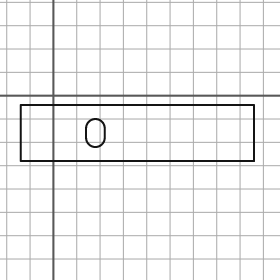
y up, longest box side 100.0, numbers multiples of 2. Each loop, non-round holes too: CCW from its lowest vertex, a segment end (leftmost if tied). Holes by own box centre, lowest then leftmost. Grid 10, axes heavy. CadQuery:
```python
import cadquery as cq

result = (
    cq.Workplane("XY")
    .moveTo(-14.0, -28.0)
    .lineTo(86.0, -28.0)
    .lineTo(86.0, -4.0)
    .lineTo(-14.0, -4.0)
    .close()
    .moveTo(14.0, -18.0)
    .threePointArc((18.0, -22.0), (22.0, -18.0))
    .lineTo(22.0, -14.0)
    .threePointArc((18.0, -10.0), (14.0, -14.0))
    .close()
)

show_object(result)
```